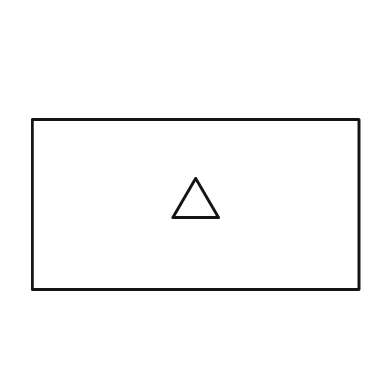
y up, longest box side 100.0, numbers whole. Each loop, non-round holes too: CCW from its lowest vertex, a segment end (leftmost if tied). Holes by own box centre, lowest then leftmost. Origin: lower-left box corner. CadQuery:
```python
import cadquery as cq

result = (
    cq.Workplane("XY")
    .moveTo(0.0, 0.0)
    .lineTo(100.0, 0.0)
    .lineTo(100.0, 52.0)
    .lineTo(0.0, 52.0)
    .close()
    .moveTo(43.0, 22.0)
    .lineTo(57.0, 22.0)
    .lineTo(50.0, 34.0)
    .close()
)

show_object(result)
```